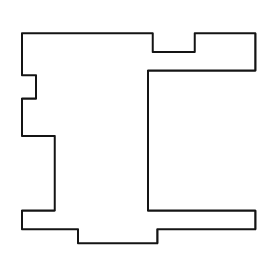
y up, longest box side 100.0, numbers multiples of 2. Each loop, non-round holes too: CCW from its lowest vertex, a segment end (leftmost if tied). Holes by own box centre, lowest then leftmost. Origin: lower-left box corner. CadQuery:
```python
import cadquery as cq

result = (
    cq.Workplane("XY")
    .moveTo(24.0, 0.0)
    .lineTo(58.0, 0.0)
    .lineTo(58.0, 6.0)
    .lineTo(100.0, 6.0)
    .lineTo(100.0, 14.0)
    .lineTo(54.0, 14.0)
    .lineTo(54.0, 74.0)
    .lineTo(100.0, 74.0)
    .lineTo(100.0, 90.0)
    .lineTo(74.0, 90.0)
    .lineTo(74.0, 82.0)
    .lineTo(56.0, 82.0)
    .lineTo(56.0, 90.0)
    .lineTo(0.0, 90.0)
    .lineTo(0.0, 72.0)
    .lineTo(6.0, 72.0)
    .lineTo(6.0, 62.0)
    .lineTo(0.0, 62.0)
    .lineTo(0.0, 46.0)
    .lineTo(14.0, 46.0)
    .lineTo(14.0, 14.0)
    .lineTo(0.0, 14.0)
    .lineTo(0.0, 6.0)
    .lineTo(24.0, 6.0)
    .close()
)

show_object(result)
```